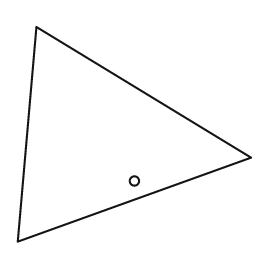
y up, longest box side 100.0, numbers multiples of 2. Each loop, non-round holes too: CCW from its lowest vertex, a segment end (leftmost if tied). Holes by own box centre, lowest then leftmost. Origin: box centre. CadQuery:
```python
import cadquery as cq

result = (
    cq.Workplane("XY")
    .moveTo(-50.0, -46.0)
    .lineTo(50.0, -10.0)
    .lineTo(-42.0, 46.0)
    .close()
    .moveTo(0.0, -20.0)
    .circle(2.0)
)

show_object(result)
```